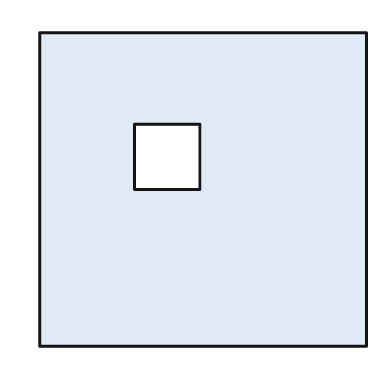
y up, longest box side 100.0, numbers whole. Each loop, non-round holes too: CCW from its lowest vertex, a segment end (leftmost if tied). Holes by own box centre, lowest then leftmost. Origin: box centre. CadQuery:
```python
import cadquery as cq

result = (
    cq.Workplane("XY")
    .moveTo(-50.0, -48.0)
    .lineTo(50.0, -48.0)
    .lineTo(50.0, 48.0)
    .lineTo(-50.0, 48.0)
    .close()
    .moveTo(-21.0, 0.0)
    .lineTo(-1.0, 0.0)
    .lineTo(-1.0, 20.0)
    .lineTo(-21.0, 20.0)
    .close()
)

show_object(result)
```